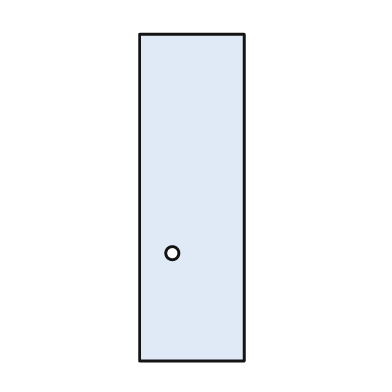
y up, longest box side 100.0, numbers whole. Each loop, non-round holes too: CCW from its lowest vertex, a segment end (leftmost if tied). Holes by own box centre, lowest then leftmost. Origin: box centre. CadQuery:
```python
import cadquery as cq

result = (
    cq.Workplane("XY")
    .moveTo(-16.0, -50.0)
    .lineTo(16.0, -50.0)
    .lineTo(16.0, 50.0)
    .lineTo(-16.0, 50.0)
    .close()
    .moveTo(-6.0, -17.0)
    .circle(2.0)
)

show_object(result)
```